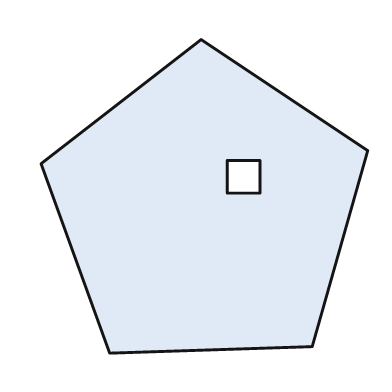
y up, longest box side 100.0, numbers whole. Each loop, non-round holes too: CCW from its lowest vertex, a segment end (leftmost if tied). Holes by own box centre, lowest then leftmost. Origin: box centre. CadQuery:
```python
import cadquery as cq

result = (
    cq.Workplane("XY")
    .moveTo(-29.0, -48.0)
    .lineTo(33.0, -46.0)
    .lineTo(50.0, 14.0)
    .lineTo(-1.0, 48.0)
    .lineTo(-50.0, 10.0)
    .close()
    .moveTo(7.0, 1.0)
    .lineTo(17.0, 1.0)
    .lineTo(17.0, 11.0)
    .lineTo(7.0, 11.0)
    .close()
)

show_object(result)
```